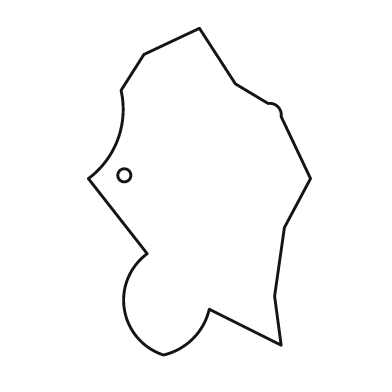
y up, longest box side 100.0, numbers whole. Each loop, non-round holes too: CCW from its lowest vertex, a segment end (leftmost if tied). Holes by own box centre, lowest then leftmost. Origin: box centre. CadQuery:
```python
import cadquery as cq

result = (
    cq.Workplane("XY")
    .moveTo(-11.0, -50.0)
    .threePointArc((-2.0, -45.0), (3.0, -36.0))
    .lineTo(25.0, -47.0)
    .lineTo(23.0, -32.0)
    .lineTo(26.0, -11.0)
    .lineTo(34.0, 4.0)
    .lineTo(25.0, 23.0)
    .threePointArc((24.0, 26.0), (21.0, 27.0))
    .lineTo(11.0, 33.0)
    .lineTo(0.0, 50.0)
    .lineTo(-17.0, 42.0)
    .lineTo(-24.0, 31.0)
    .threePointArc((-25.0, 16.0), (-34.0, 4.0))
    .lineTo(-16.0, -19.0)
    .threePointArc((-23.0, -36.0), (-11.0, -50.0))
    .close()
    .moveTo(-23.0, 5.0)
    .circle(2.0)
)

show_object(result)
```